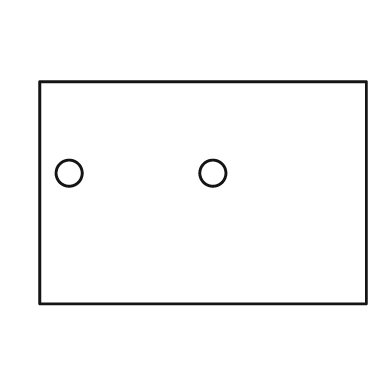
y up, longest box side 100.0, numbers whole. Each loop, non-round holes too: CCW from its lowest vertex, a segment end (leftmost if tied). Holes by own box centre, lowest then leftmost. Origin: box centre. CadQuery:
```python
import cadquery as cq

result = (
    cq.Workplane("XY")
    .moveTo(-50.0, -34.0)
    .lineTo(50.0, -34.0)
    .lineTo(50.0, 34.0)
    .lineTo(-50.0, 34.0)
    .close()
    .moveTo(-41.0, 6.0)
    .circle(4.0)
    .moveTo(3.0, 6.0)
    .circle(4.0)
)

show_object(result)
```